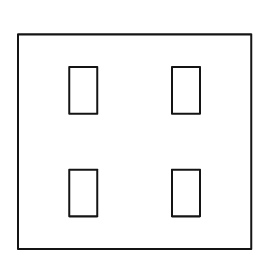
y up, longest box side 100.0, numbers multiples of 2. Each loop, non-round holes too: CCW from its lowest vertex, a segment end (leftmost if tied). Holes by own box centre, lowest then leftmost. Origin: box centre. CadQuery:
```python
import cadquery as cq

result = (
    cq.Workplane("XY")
    .moveTo(-50.0, -46.0)
    .lineTo(50.0, -46.0)
    .lineTo(50.0, 46.0)
    .lineTo(-50.0, 46.0)
    .close()
    .moveTo(-28.0, -32.0)
    .lineTo(-16.0, -32.0)
    .lineTo(-16.0, -12.0)
    .lineTo(-28.0, -12.0)
    .close()
    .moveTo(16.0, -32.0)
    .lineTo(28.0, -32.0)
    .lineTo(28.0, -12.0)
    .lineTo(16.0, -12.0)
    .close()
    .moveTo(-28.0, 12.0)
    .lineTo(-16.0, 12.0)
    .lineTo(-16.0, 32.0)
    .lineTo(-28.0, 32.0)
    .close()
    .moveTo(16.0, 12.0)
    .lineTo(28.0, 12.0)
    .lineTo(28.0, 32.0)
    .lineTo(16.0, 32.0)
    .close()
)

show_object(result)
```